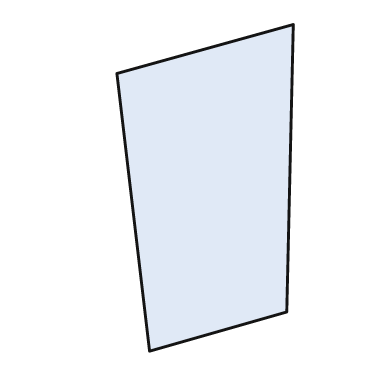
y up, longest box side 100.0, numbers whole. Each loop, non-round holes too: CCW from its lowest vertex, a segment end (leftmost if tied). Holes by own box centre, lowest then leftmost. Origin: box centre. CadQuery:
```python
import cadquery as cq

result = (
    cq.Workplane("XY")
    .moveTo(-17.0, -50.0)
    .lineTo(25.0, -38.0)
    .lineTo(27.0, 50.0)
    .lineTo(-27.0, 35.0)
    .close()
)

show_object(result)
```